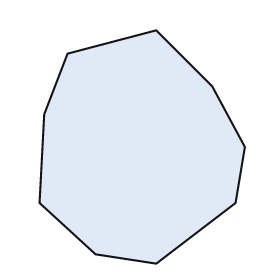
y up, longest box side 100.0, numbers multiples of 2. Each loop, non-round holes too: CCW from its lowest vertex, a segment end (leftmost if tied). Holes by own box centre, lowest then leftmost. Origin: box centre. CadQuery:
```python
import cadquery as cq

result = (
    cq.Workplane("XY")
    .moveTo(6.0, -50.0)
    .lineTo(40.0, -24.0)
    .lineTo(44.0, 0.0)
    .lineTo(30.0, 26.0)
    .lineTo(6.0, 50.0)
    .lineTo(-32.0, 40.0)
    .lineTo(-42.0, 14.0)
    .lineTo(-44.0, -24.0)
    .lineTo(-20.0, -46.0)
    .close()
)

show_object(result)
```